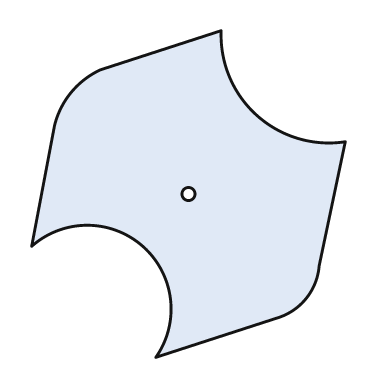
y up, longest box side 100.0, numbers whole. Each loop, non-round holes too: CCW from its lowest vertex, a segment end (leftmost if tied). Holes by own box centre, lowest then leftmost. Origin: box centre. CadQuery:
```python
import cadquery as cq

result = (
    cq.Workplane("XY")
    .moveTo(-10.0, -50.0)
    .lineTo(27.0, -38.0)
    .threePointArc((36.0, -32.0), (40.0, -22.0))
    .lineTo(48.0, 16.0)
    .threePointArc((21.0, 24.0), (10.0, 50.0))
    .lineTo(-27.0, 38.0)
    .threePointArc((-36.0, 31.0), (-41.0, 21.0))
    .lineTo(-48.0, -16.0)
    .threePointArc((-14.0, -16.0), (-10.0, -50.0))
    .close()
    .moveTo(0.0, 0.0)
    .circle(2.0)
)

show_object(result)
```